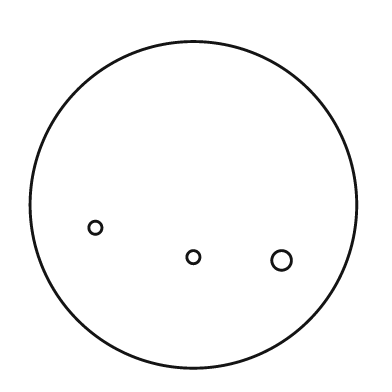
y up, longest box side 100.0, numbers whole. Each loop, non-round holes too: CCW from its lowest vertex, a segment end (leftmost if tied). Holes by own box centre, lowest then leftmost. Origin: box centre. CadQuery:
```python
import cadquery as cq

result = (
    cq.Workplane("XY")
    .moveTo(0.0, 0.0)
    .circle(50.0)
    .moveTo(27.0, -17.0)
    .circle(3.0)
    .moveTo(0.0, -16.0)
    .circle(2.0)
    .moveTo(-30.0, -7.0)
    .circle(2.0)
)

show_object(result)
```